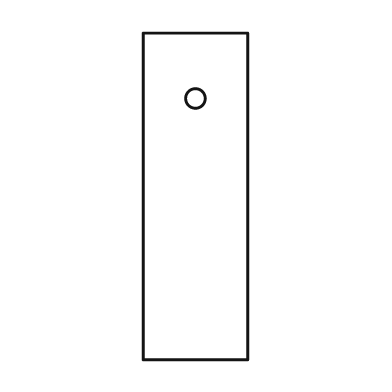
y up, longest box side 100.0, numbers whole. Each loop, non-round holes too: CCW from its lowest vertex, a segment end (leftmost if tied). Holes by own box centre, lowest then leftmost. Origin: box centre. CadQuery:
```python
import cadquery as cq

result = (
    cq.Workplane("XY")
    .moveTo(-16.0, -50.0)
    .lineTo(16.0, -50.0)
    .lineTo(16.0, 50.0)
    .lineTo(-16.0, 50.0)
    .close()
    .moveTo(0.0, 30.0)
    .circle(3.0)
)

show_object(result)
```